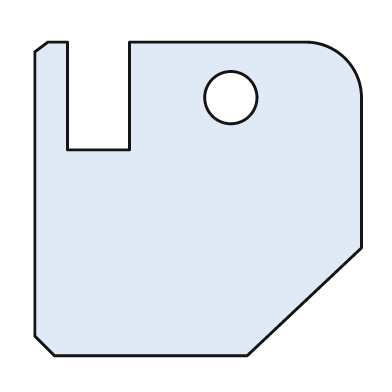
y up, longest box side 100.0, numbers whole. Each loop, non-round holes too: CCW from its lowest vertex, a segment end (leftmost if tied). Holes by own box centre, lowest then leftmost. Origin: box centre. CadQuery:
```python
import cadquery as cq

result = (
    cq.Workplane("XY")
    .moveTo(-44.0, -48.0)
    .lineTo(15.0, -48.0)
    .lineTo(50.0, -15.0)
    .lineTo(50.0, 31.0)
    .threePointArc((45.0, 43.0), (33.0, 48.0))
    .lineTo(-21.0, 48.0)
    .lineTo(-21.0, 15.0)
    .lineTo(-40.0, 15.0)
    .lineTo(-40.0, 48.0)
    .lineTo(-46.0, 48.0)
    .lineTo(-50.0, 45.0)
    .lineTo(-50.0, -42.0)
    .close()
    .moveTo(10.0, 31.0)
    .circle(8.0)
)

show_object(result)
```